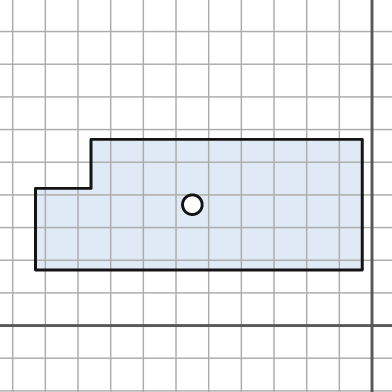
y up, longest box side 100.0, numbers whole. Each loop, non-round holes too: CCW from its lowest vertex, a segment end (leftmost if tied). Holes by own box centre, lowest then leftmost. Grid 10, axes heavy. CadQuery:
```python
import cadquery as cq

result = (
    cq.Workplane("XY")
    .moveTo(-103.0, 17.0)
    .lineTo(-3.0, 17.0)
    .lineTo(-3.0, 57.0)
    .lineTo(-86.0, 57.0)
    .lineTo(-86.0, 42.0)
    .lineTo(-103.0, 42.0)
    .close()
    .moveTo(-55.0, 37.0)
    .circle(3.0)
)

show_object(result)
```